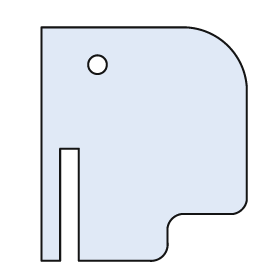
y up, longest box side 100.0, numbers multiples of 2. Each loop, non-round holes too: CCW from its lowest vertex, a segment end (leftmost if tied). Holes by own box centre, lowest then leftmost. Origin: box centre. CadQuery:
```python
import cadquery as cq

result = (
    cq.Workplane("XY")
    .moveTo(-44.0, -50.0)
    .lineTo(-36.0, -50.0)
    .lineTo(-36.0, -2.0)
    .lineTo(-28.0, -2.0)
    .lineTo(-28.0, -50.0)
    .lineTo(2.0, -50.0)
    .threePointArc((8.0, -48.0), (10.0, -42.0))
    .lineTo(10.0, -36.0)
    .threePointArc((12.0, -32.0), (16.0, -30.0))
    .lineTo(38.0, -30.0)
    .threePointArc((42.0, -28.0), (44.0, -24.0))
    .lineTo(44.0, 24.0)
    .threePointArc((36.0, 42.0), (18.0, 50.0))
    .lineTo(-44.0, 50.0)
    .close()
    .moveTo(-20.0, 34.0)
    .circle(4.0)
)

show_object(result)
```